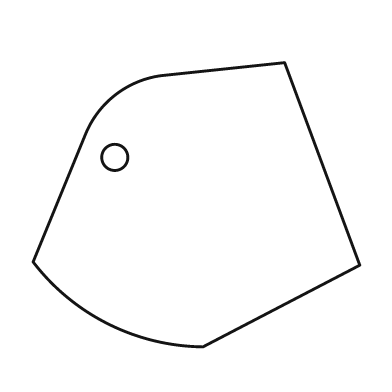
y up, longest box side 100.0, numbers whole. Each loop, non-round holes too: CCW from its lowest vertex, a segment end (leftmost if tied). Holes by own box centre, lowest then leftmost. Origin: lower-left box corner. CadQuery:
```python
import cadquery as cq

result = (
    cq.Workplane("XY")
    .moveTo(52.0, 0.0)
    .lineTo(100.0, 25.0)
    .lineTo(77.0, 87.0)
    .lineTo(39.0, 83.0)
    .threePointArc((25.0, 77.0), (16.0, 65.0))
    .lineTo(0.0, 26.0)
    .threePointArc((23.0, 7.0), (52.0, 0.0))
    .close()
    .moveTo(25.0, 58.0)
    .circle(4.0)
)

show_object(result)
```